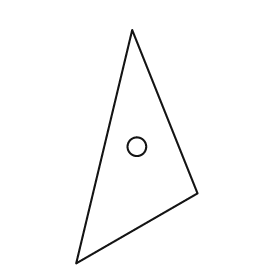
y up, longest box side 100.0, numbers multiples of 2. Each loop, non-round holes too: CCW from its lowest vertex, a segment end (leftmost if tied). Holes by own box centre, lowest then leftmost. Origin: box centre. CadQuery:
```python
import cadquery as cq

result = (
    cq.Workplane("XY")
    .moveTo(-26.0, -50.0)
    .lineTo(26.0, -20.0)
    .lineTo(-2.0, 50.0)
    .close()
    .moveTo(0.0, 0.0)
    .circle(4.0)
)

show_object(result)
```